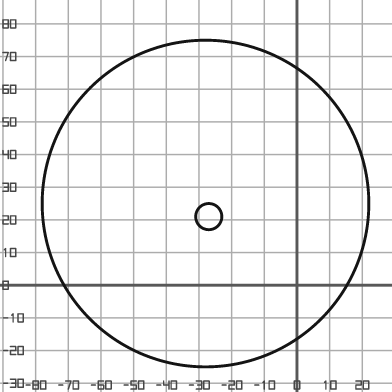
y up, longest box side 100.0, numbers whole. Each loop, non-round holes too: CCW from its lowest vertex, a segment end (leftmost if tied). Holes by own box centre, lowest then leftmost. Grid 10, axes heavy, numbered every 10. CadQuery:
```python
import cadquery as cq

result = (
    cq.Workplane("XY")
    .moveTo(-28.0, 25.0)
    .circle(50.0)
    .moveTo(-27.0, 21.0)
    .circle(4.0)
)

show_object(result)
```